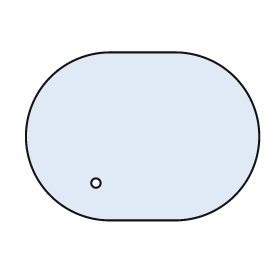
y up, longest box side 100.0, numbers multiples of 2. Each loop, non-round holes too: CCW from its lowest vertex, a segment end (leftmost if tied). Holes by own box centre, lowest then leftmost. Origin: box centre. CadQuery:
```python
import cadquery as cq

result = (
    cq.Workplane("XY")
    .moveTo(-14.0, -36.0)
    .lineTo(14.0, -36.0)
    .threePointArc((50.0, 0.0), (14.0, 36.0))
    .lineTo(-14.0, 36.0)
    .threePointArc((-50.0, 0.0), (-14.0, -36.0))
    .close()
    .moveTo(-20.0, -20.0)
    .circle(2.0)
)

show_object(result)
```